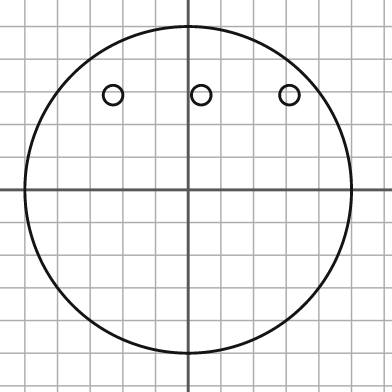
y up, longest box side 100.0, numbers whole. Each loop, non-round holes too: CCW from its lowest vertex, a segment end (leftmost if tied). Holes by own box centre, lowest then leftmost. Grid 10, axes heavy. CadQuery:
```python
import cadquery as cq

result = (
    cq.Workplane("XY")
    .moveTo(0.0, 0.0)
    .circle(50.0)
    .moveTo(-23.0, 29.0)
    .circle(3.0)
    .moveTo(4.0, 29.0)
    .circle(3.0)
    .moveTo(31.0, 29.0)
    .circle(3.0)
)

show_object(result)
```